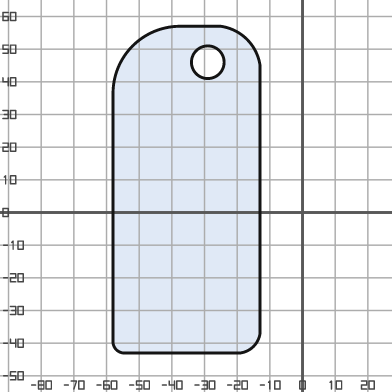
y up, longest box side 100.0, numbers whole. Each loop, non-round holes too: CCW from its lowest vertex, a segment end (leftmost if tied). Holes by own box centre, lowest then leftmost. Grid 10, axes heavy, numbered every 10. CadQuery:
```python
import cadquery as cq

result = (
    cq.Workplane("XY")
    .moveTo(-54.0, -43.0)
    .lineTo(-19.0, -43.0)
    .threePointArc((-15.0, -41.0), (-13.0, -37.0))
    .lineTo(-13.0, 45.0)
    .threePointArc((-17.0, 53.0), (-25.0, 57.0))
    .lineTo(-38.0, 57.0)
    .threePointArc((-52.0, 51.0), (-58.0, 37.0))
    .lineTo(-58.0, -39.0)
    .threePointArc((-57.0, -42.0), (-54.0, -43.0))
    .close()
    .moveTo(-29.0, 46.0)
    .circle(5.0)
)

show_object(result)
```